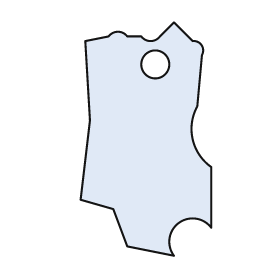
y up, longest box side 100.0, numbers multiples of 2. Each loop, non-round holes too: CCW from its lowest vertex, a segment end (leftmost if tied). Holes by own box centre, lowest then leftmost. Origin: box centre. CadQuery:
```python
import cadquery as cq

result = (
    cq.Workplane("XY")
    .moveTo(12.0, -50.0)
    .threePointArc((14.0, -36.0), (28.0, -38.0))
    .lineTo(28.0, -12.0)
    .threePointArc((20.0, 0.0), (22.0, 14.0))
    .lineTo(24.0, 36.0)
    .threePointArc((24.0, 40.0), (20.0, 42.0))
    .lineTo(12.0, 50.0)
    .lineTo(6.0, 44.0)
    .threePointArc((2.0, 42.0), (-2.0, 44.0))
    .lineTo(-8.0, 44.0)
    .threePointArc((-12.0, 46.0), (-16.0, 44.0))
    .lineTo(-26.0, 42.0)
    .lineTo(-24.0, 8.0)
    .lineTo(-28.0, -26.0)
    .lineTo(-14.0, -30.0)
    .lineTo(-8.0, -46.0)
    .close()
    .moveTo(4.0, 32.0)
    .circle(6.0)
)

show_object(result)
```